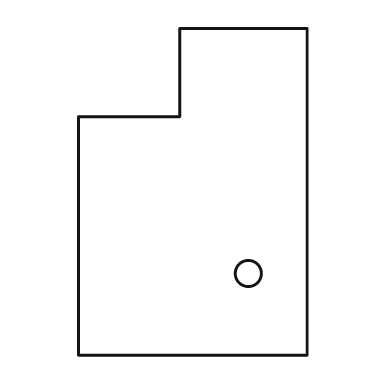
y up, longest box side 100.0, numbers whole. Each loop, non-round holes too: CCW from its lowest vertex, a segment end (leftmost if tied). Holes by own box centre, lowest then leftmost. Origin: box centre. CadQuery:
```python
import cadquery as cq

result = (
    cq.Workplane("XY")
    .moveTo(-35.0, -50.0)
    .lineTo(35.0, -50.0)
    .lineTo(35.0, 50.0)
    .lineTo(-4.0, 50.0)
    .lineTo(-4.0, 23.0)
    .lineTo(-35.0, 23.0)
    .close()
    .moveTo(17.0, -25.0)
    .circle(4.0)
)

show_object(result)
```